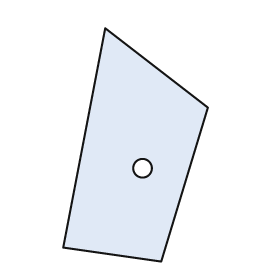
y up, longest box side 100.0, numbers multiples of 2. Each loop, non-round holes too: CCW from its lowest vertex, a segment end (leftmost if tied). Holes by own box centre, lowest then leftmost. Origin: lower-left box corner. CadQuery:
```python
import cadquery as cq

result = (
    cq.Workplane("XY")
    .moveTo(42.0, 0.0)
    .lineTo(62.0, 66.0)
    .lineTo(18.0, 100.0)
    .lineTo(0.0, 6.0)
    .close()
    .moveTo(34.0, 40.0)
    .circle(4.0)
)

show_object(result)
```